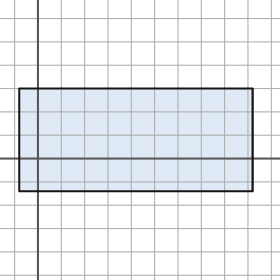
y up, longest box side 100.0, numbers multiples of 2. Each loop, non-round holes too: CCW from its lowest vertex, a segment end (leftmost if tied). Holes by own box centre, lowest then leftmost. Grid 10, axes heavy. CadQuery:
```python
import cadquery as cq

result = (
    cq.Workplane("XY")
    .moveTo(-8.0, -14.0)
    .lineTo(92.0, -14.0)
    .lineTo(92.0, 30.0)
    .lineTo(-8.0, 30.0)
    .close()
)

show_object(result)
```